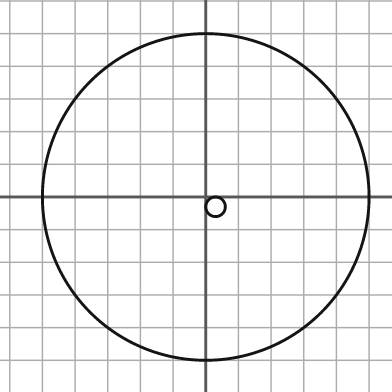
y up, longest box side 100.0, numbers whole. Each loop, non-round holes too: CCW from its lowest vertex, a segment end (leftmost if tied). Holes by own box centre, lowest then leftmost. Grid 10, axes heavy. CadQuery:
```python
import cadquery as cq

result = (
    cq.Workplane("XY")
    .moveTo(0.0, 0.0)
    .circle(50.0)
    .moveTo(3.0, -3.0)
    .circle(3.0)
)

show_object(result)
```